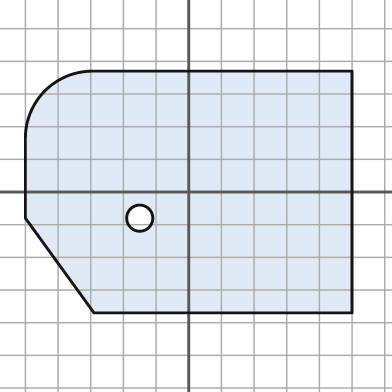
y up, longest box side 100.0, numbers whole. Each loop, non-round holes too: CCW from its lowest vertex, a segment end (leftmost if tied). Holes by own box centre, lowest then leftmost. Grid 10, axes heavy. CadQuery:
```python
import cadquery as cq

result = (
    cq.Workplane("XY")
    .moveTo(-29.0, -37.0)
    .lineTo(50.0, -37.0)
    .lineTo(50.0, 37.0)
    .lineTo(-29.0, 37.0)
    .threePointArc((-44.0, 31.0), (-50.0, 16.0))
    .lineTo(-50.0, -8.0)
    .close()
    .moveTo(-15.0, -8.0)
    .circle(4.0)
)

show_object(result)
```